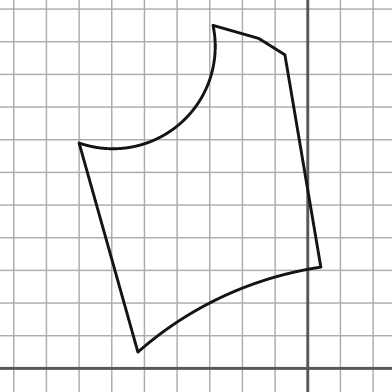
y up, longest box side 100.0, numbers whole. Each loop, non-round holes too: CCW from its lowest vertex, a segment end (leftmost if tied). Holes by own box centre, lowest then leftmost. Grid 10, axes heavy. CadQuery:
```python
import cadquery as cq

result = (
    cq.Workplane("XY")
    .moveTo(-52.0, 5.0)
    .threePointArc((-26.0, 22.0), (4.0, 31.0))
    .lineTo(-7.0, 96.0)
    .lineTo(-15.0, 101.0)
    .lineTo(-29.0, 105.0)
    .threePointArc((-39.0, 75.0), (-70.0, 69.0))
    .close()
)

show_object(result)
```